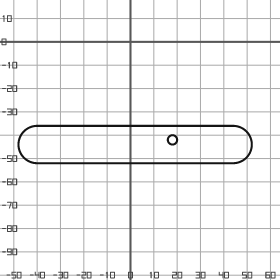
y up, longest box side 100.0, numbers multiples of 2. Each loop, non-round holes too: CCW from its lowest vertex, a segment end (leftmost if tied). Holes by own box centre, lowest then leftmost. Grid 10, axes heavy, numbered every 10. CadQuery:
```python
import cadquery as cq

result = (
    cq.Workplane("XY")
    .moveTo(-40.0, -52.0)
    .lineTo(44.0, -52.0)
    .threePointArc((52.0, -44.0), (44.0, -36.0))
    .lineTo(-40.0, -36.0)
    .threePointArc((-48.0, -44.0), (-40.0, -52.0))
    .close()
    .moveTo(18.0, -42.0)
    .circle(2.0)
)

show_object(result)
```